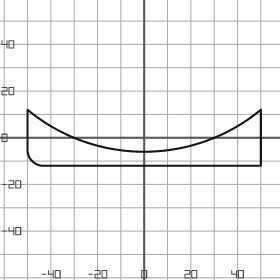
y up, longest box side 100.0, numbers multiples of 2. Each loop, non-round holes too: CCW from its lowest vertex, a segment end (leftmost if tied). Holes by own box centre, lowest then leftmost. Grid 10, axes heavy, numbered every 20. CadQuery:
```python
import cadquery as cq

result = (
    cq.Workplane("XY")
    .moveTo(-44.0, -12.0)
    .lineTo(50.0, -12.0)
    .lineTo(50.0, 12.0)
    .threePointArc((0.0, -6.0), (-50.0, 12.0))
    .lineTo(-50.0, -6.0)
    .threePointArc((-48.0, -10.0), (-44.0, -12.0))
    .close()
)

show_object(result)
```